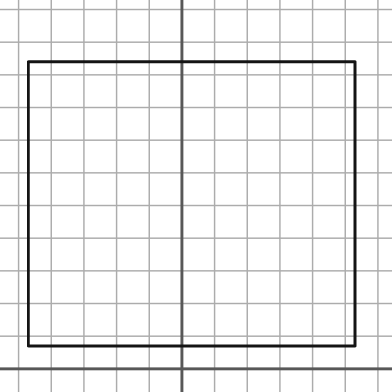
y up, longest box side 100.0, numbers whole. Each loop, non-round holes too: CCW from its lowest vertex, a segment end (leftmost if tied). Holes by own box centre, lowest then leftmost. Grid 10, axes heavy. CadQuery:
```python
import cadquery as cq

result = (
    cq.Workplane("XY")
    .moveTo(-47.0, 7.0)
    .lineTo(53.0, 7.0)
    .lineTo(53.0, 94.0)
    .lineTo(-47.0, 94.0)
    .close()
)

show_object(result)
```